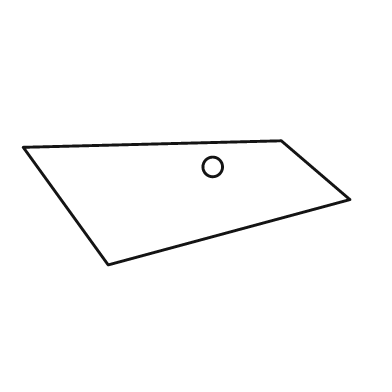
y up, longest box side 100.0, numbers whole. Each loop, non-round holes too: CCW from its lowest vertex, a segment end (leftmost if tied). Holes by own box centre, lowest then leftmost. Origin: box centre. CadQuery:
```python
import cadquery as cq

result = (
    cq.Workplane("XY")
    .moveTo(-24.0, -19.0)
    .lineTo(50.0, 1.0)
    .lineTo(29.0, 19.0)
    .lineTo(-50.0, 17.0)
    .close()
    .moveTo(8.0, 11.0)
    .circle(3.0)
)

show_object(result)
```